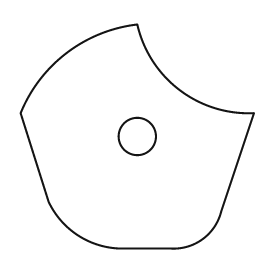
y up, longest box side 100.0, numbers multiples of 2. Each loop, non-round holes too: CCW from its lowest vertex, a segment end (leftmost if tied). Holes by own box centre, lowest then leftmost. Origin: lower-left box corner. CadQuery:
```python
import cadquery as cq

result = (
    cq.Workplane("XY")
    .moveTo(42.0, 0.0)
    .lineTo(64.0, 0.0)
    .threePointArc((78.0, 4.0), (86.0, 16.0))
    .lineTo(100.0, 58.0)
    .threePointArc((68.0, 68.0), (50.0, 96.0))
    .threePointArc((20.0, 84.0), (0.0, 58.0))
    .lineTo(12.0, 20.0)
    .threePointArc((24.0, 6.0), (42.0, 0.0))
    .close()
    .moveTo(50.0, 48.0)
    .circle(8.0)
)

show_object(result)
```